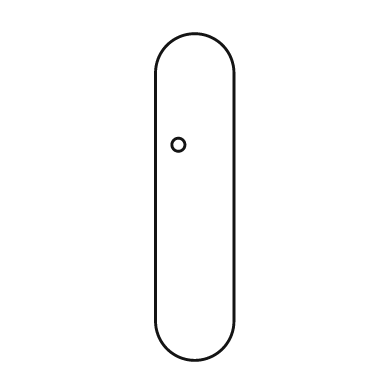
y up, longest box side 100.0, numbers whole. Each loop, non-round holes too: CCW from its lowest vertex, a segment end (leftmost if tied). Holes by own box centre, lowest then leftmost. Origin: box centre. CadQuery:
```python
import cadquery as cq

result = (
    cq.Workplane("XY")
    .moveTo(-12.0, -38.0)
    .threePointArc((0.0, -50.0), (12.0, -38.0))
    .lineTo(12.0, 38.0)
    .threePointArc((0.0, 50.0), (-12.0, 38.0))
    .close()
    .moveTo(-5.0, 16.0)
    .circle(2.0)
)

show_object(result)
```